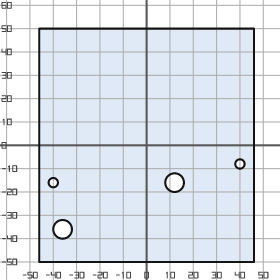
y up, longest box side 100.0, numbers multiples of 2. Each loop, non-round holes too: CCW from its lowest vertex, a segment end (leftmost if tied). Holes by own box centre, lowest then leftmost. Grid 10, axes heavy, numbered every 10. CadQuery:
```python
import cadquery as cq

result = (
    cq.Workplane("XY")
    .moveTo(-46.0, -50.0)
    .lineTo(46.0, -50.0)
    .lineTo(46.0, 50.0)
    .lineTo(-46.0, 50.0)
    .close()
    .moveTo(-36.0, -36.0)
    .circle(4.0)
    .moveTo(-40.0, -16.0)
    .circle(2.0)
    .moveTo(12.0, -16.0)
    .circle(4.0)
    .moveTo(40.0, -8.0)
    .circle(2.0)
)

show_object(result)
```